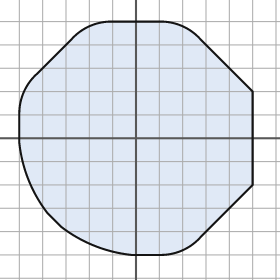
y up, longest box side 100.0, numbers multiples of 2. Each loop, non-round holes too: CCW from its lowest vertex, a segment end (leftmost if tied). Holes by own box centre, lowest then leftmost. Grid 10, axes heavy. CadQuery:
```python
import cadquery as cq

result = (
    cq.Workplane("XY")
    .moveTo(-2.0, -50.0)
    .lineTo(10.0, -50.0)
    .threePointArc((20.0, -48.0), (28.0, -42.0))
    .lineTo(50.0, -20.0)
    .lineTo(50.0, 20.0)
    .lineTo(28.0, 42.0)
    .threePointArc((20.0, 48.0), (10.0, 50.0))
    .lineTo(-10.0, 50.0)
    .threePointArc((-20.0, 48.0), (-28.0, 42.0))
    .lineTo(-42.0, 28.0)
    .threePointArc((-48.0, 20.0), (-50.0, 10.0))
    .lineTo(-50.0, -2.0)
    .threePointArc((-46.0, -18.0), (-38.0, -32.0))
    .lineTo(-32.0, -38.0)
    .threePointArc((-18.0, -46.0), (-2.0, -50.0))
    .close()
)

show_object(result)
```